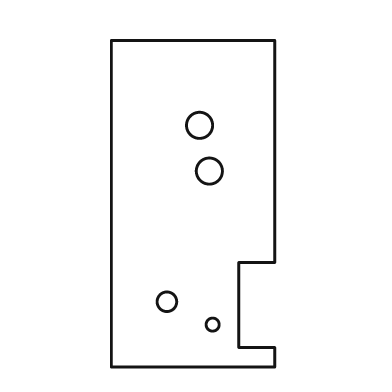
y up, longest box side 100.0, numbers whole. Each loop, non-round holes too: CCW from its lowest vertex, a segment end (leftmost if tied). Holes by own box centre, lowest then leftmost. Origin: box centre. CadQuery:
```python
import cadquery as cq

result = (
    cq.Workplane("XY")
    .moveTo(-25.0, -50.0)
    .lineTo(25.0, -50.0)
    .lineTo(25.0, -44.0)
    .lineTo(14.0, -44.0)
    .lineTo(14.0, -18.0)
    .lineTo(25.0, -18.0)
    .lineTo(25.0, 50.0)
    .lineTo(-25.0, 50.0)
    .close()
    .moveTo(6.0, -37.0)
    .circle(2.0)
    .moveTo(-8.0, -30.0)
    .circle(3.0)
    .moveTo(5.0, 10.0)
    .circle(4.0)
    .moveTo(2.0, 24.0)
    .circle(4.0)
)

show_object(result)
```